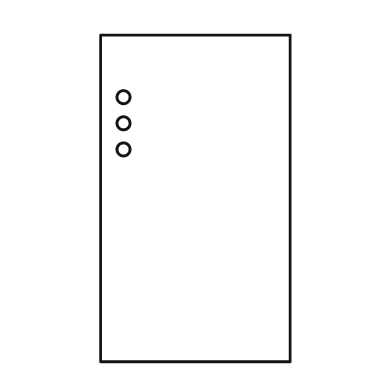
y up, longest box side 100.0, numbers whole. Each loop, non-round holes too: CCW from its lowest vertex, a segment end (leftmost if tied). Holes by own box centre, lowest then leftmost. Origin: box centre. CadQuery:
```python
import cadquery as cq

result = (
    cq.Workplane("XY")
    .moveTo(-29.0, -50.0)
    .lineTo(29.0, -50.0)
    .lineTo(29.0, 50.0)
    .lineTo(-29.0, 50.0)
    .close()
    .moveTo(-22.0, 15.0)
    .circle(2.0)
    .moveTo(-22.0, 23.0)
    .circle(2.0)
    .moveTo(-22.0, 31.0)
    .circle(2.0)
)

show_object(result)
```